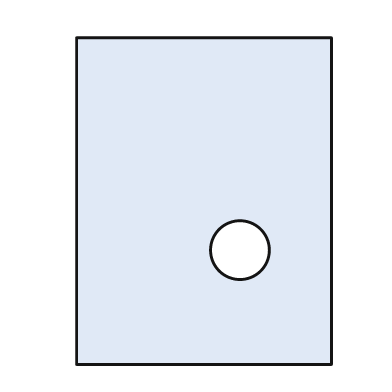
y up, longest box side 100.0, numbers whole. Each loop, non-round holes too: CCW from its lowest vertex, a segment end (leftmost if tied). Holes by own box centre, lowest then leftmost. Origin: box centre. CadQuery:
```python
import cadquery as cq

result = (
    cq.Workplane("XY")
    .moveTo(-39.0, -50.0)
    .lineTo(39.0, -50.0)
    .lineTo(39.0, 50.0)
    .lineTo(-39.0, 50.0)
    .close()
    .moveTo(11.0, -15.0)
    .circle(9.0)
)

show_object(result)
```